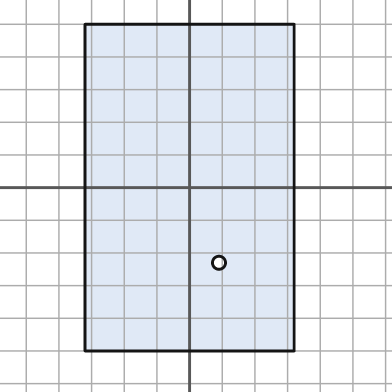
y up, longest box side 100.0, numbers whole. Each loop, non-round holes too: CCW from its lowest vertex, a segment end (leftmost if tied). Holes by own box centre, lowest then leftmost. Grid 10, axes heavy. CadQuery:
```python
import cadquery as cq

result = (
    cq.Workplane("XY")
    .moveTo(-32.0, -50.0)
    .lineTo(32.0, -50.0)
    .lineTo(32.0, 50.0)
    .lineTo(-32.0, 50.0)
    .close()
    .moveTo(9.0, -23.0)
    .circle(2.0)
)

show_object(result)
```